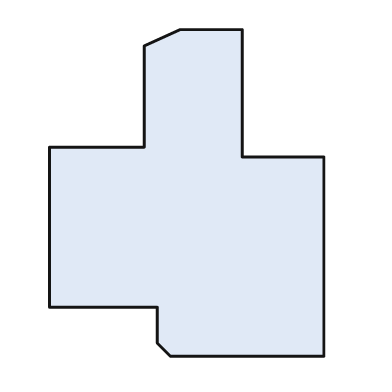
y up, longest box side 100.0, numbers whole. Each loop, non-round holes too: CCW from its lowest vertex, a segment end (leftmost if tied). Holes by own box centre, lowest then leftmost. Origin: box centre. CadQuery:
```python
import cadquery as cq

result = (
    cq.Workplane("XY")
    .moveTo(-5.0, -50.0)
    .lineTo(42.0, -50.0)
    .lineTo(42.0, 11.0)
    .lineTo(17.0, 11.0)
    .lineTo(17.0, 50.0)
    .lineTo(-2.0, 50.0)
    .lineTo(-13.0, 45.0)
    .lineTo(-13.0, 14.0)
    .lineTo(-42.0, 14.0)
    .lineTo(-42.0, -35.0)
    .lineTo(-9.0, -35.0)
    .lineTo(-9.0, -46.0)
    .close()
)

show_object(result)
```